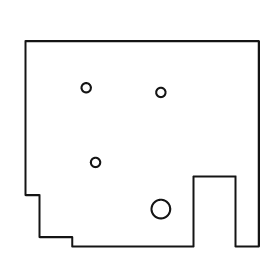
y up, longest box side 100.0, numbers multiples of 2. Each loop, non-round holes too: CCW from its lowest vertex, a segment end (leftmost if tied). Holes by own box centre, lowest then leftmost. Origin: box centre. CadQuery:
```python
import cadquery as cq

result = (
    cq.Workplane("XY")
    .moveTo(-30.0, -44.0)
    .lineTo(22.0, -44.0)
    .lineTo(22.0, -14.0)
    .lineTo(40.0, -14.0)
    .lineTo(40.0, -44.0)
    .lineTo(50.0, -44.0)
    .lineTo(50.0, 44.0)
    .lineTo(-50.0, 44.0)
    .lineTo(-50.0, -22.0)
    .lineTo(-44.0, -22.0)
    .lineTo(-44.0, -40.0)
    .lineTo(-30.0, -40.0)
    .close()
    .moveTo(8.0, -28.0)
    .circle(4.0)
    .moveTo(-20.0, -8.0)
    .circle(2.0)
    .moveTo(8.0, 22.0)
    .circle(2.0)
    .moveTo(-24.0, 24.0)
    .circle(2.0)
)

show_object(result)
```